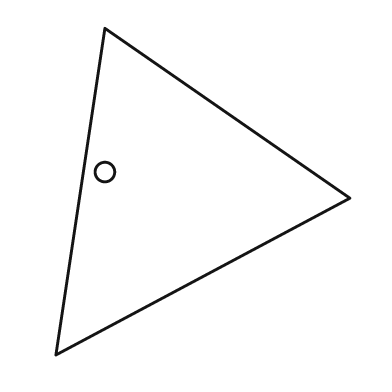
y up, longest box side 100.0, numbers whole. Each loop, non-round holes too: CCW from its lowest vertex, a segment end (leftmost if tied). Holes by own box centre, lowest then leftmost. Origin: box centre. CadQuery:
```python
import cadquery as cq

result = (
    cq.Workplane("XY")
    .moveTo(-45.0, -50.0)
    .lineTo(45.0, -2.0)
    .lineTo(-30.0, 50.0)
    .close()
    .moveTo(-30.0, 6.0)
    .circle(3.0)
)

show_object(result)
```